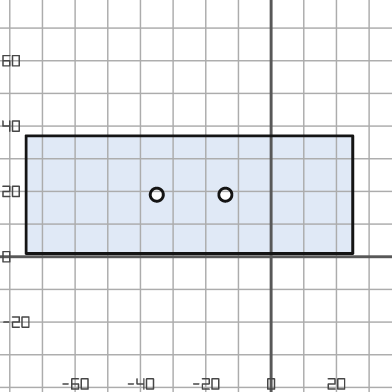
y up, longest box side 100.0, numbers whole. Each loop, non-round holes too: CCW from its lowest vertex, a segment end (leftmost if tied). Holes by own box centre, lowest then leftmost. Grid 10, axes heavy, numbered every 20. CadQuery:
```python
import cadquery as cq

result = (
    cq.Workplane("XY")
    .moveTo(-75.0, 1.0)
    .lineTo(25.0, 1.0)
    .lineTo(25.0, 37.0)
    .lineTo(-75.0, 37.0)
    .close()
    .moveTo(-35.0, 19.0)
    .circle(2.0)
    .moveTo(-14.0, 19.0)
    .circle(2.0)
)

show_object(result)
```